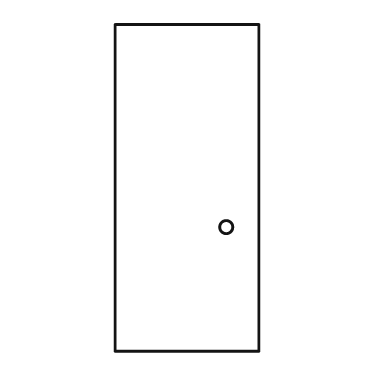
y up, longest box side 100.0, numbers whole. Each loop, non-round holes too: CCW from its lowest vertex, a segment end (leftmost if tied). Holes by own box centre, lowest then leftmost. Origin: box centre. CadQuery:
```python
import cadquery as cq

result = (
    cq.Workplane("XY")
    .moveTo(-22.0, -50.0)
    .lineTo(22.0, -50.0)
    .lineTo(22.0, 50.0)
    .lineTo(-22.0, 50.0)
    .close()
    .moveTo(12.0, -12.0)
    .circle(2.0)
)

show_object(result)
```